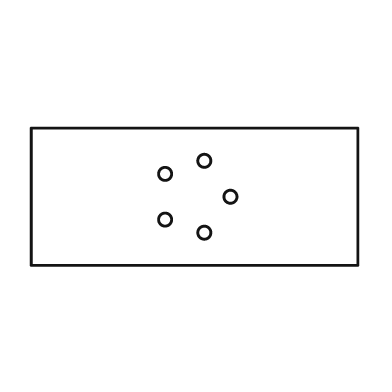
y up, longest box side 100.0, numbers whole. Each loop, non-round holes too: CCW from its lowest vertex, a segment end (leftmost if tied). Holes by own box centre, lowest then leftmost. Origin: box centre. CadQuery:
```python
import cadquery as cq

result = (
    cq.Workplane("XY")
    .moveTo(-50.0, -21.0)
    .lineTo(50.0, -21.0)
    .lineTo(50.0, 21.0)
    .lineTo(-50.0, 21.0)
    .close()
    .moveTo(3.0, -11.0)
    .circle(2.0)
    .moveTo(-9.0, -7.0)
    .circle(2.0)
    .moveTo(11.0, 0.0)
    .circle(2.0)
    .moveTo(-9.0, 7.0)
    .circle(2.0)
    .moveTo(3.0, 11.0)
    .circle(2.0)
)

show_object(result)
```